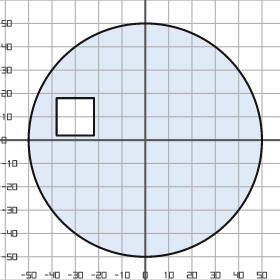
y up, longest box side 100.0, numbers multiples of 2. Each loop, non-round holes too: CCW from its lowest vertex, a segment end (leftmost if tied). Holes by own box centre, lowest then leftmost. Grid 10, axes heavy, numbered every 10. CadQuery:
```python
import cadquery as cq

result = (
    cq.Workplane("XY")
    .moveTo(0.0, 0.0)
    .circle(50.0)
    .moveTo(-38.0, 2.0)
    .lineTo(-22.0, 2.0)
    .lineTo(-22.0, 18.0)
    .lineTo(-38.0, 18.0)
    .close()
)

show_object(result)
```